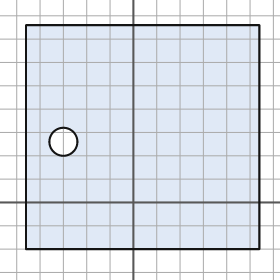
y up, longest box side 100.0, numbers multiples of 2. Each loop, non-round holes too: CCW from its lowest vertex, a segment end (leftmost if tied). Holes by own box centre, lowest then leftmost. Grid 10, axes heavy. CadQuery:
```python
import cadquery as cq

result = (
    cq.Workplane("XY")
    .moveTo(-46.0, -20.0)
    .lineTo(54.0, -20.0)
    .lineTo(54.0, 76.0)
    .lineTo(-46.0, 76.0)
    .close()
    .moveTo(-30.0, 26.0)
    .circle(6.0)
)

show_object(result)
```